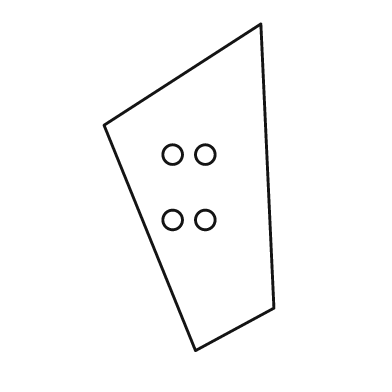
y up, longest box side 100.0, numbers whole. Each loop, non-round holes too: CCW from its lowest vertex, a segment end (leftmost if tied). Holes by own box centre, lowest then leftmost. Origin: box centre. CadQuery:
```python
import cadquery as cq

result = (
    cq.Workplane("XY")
    .moveTo(2.0, -50.0)
    .lineTo(26.0, -37.0)
    .lineTo(22.0, 50.0)
    .lineTo(-26.0, 19.0)
    .close()
    .moveTo(-5.0, -10.0)
    .circle(3.0)
    .moveTo(5.0, -10.0)
    .circle(3.0)
    .moveTo(-5.0, 10.0)
    .circle(3.0)
    .moveTo(5.0, 10.0)
    .circle(3.0)
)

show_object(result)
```